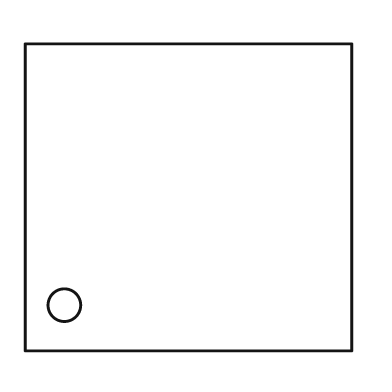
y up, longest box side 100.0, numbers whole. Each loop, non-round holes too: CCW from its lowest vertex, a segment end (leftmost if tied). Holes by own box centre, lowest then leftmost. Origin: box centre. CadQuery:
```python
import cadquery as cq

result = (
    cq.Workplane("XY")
    .moveTo(-50.0, -47.0)
    .lineTo(50.0, -47.0)
    .lineTo(50.0, 47.0)
    .lineTo(-50.0, 47.0)
    .close()
    .moveTo(-38.0, -33.0)
    .circle(5.0)
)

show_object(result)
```